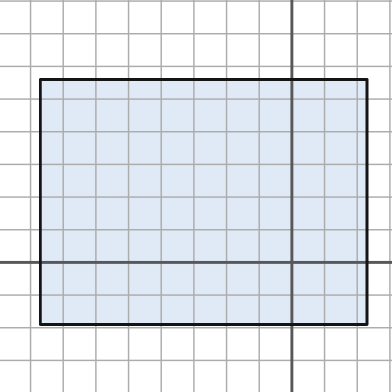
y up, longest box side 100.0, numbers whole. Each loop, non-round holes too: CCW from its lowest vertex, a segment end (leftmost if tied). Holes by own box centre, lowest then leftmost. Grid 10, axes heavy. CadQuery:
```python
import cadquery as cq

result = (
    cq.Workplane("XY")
    .moveTo(-77.0, -19.0)
    .lineTo(23.0, -19.0)
    .lineTo(23.0, 56.0)
    .lineTo(-77.0, 56.0)
    .close()
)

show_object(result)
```